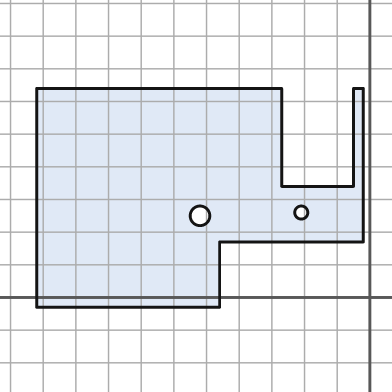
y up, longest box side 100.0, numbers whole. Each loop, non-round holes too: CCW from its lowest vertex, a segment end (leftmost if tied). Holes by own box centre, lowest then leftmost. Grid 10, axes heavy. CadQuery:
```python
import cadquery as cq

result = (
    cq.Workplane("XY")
    .moveTo(-102.0, -3.0)
    .lineTo(-46.0, -3.0)
    .lineTo(-46.0, 17.0)
    .lineTo(-2.0, 17.0)
    .lineTo(-2.0, 64.0)
    .lineTo(-5.0, 64.0)
    .lineTo(-5.0, 34.0)
    .lineTo(-27.0, 34.0)
    .lineTo(-27.0, 64.0)
    .lineTo(-102.0, 64.0)
    .close()
    .moveTo(-52.0, 25.0)
    .circle(3.0)
    .moveTo(-21.0, 26.0)
    .circle(2.0)
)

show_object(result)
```